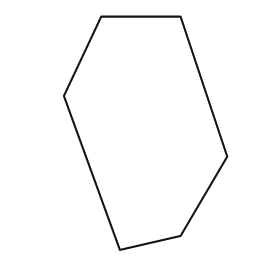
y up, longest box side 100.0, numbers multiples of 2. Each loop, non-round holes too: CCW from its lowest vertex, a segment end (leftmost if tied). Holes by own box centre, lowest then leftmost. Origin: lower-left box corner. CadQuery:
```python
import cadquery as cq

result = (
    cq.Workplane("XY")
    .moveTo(24.0, 0.0)
    .lineTo(50.0, 6.0)
    .lineTo(70.0, 40.0)
    .lineTo(50.0, 100.0)
    .lineTo(16.0, 100.0)
    .lineTo(0.0, 66.0)
    .close()
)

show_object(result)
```